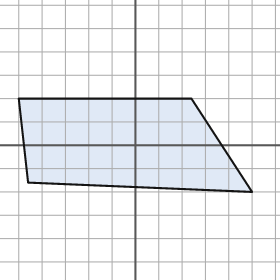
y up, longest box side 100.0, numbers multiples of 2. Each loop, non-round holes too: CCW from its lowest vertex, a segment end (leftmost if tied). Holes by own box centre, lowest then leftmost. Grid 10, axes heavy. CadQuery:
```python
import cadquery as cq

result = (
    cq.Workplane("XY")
    .moveTo(50.0, -20.0)
    .lineTo(24.0, 20.0)
    .lineTo(-50.0, 20.0)
    .lineTo(-46.0, -16.0)
    .close()
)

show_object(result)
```